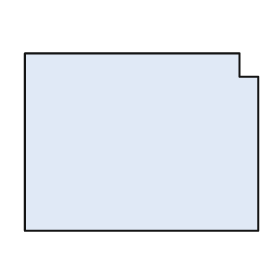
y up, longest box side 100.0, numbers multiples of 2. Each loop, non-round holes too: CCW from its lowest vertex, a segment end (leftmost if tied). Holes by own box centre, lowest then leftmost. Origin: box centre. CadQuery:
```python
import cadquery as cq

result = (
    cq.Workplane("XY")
    .moveTo(-50.0, -38.0)
    .lineTo(50.0, -38.0)
    .lineTo(50.0, 28.0)
    .lineTo(42.0, 28.0)
    .lineTo(42.0, 38.0)
    .lineTo(-50.0, 38.0)
    .close()
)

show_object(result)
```